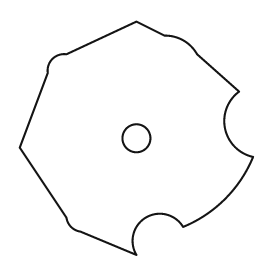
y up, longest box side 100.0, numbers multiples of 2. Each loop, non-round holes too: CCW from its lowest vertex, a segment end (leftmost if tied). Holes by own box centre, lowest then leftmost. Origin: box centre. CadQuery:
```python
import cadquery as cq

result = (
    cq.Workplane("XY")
    .moveTo(0.0, -50.0)
    .threePointArc((4.0, -34.0), (20.0, -38.0))
    .threePointArc((38.0, -26.0), (50.0, -8.0))
    .threePointArc((38.0, 4.0), (44.0, 20.0))
    .lineTo(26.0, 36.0)
    .threePointArc((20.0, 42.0), (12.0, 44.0))
    .lineTo(0.0, 50.0)
    .lineTo(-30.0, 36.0)
    .threePointArc((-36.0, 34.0), (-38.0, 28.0))
    .lineTo(-50.0, -4.0)
    .lineTo(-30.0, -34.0)
    .threePointArc((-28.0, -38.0), (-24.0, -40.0))
    .close()
    .moveTo(0.0, 0.0)
    .circle(6.0)
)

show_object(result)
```